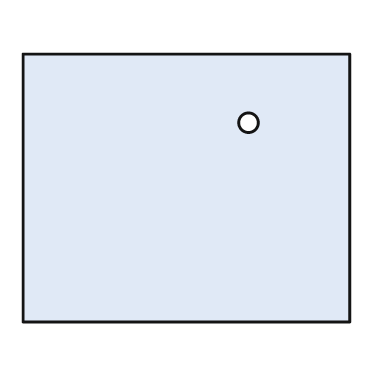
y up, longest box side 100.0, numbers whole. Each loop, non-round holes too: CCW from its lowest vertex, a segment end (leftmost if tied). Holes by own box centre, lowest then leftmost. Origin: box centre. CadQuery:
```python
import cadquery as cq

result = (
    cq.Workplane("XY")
    .moveTo(-50.0, -41.0)
    .lineTo(50.0, -41.0)
    .lineTo(50.0, 41.0)
    .lineTo(-50.0, 41.0)
    .close()
    .moveTo(19.0, 20.0)
    .circle(3.0)
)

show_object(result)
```